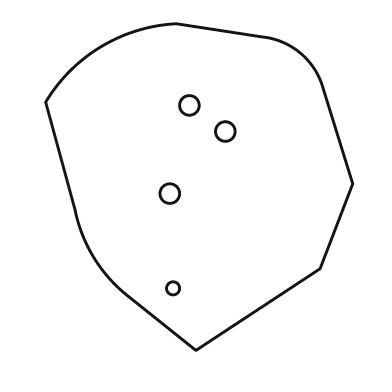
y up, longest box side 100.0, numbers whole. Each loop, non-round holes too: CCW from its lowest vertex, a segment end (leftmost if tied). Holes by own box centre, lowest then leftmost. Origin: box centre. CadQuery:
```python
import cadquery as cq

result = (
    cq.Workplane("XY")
    .moveTo(-1.0, -50.0)
    .lineTo(37.0, -25.0)
    .lineTo(47.0, 1.0)
    .lineTo(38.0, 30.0)
    .threePointArc((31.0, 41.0), (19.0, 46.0))
    .lineTo(-7.0, 50.0)
    .threePointArc((-30.0, 43.0), (-47.0, 26.0))
    .lineTo(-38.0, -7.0)
    .threePointArc((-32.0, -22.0), (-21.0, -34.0))
    .close()
    .moveTo(-8.0, -31.0)
    .circle(2.0)
    .moveTo(-9.0, -2.0)
    .circle(3.0)
    .moveTo(8.0, 17.0)
    .circle(3.0)
    .moveTo(-3.0, 25.0)
    .circle(3.0)
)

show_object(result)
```